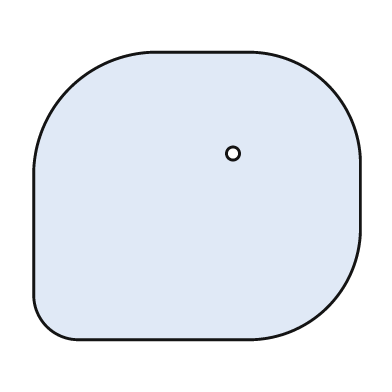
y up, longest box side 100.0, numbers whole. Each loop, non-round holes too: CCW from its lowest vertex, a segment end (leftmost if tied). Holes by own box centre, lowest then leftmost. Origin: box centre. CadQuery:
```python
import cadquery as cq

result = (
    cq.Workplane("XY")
    .moveTo(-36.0, -44.0)
    .lineTo(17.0, -44.0)
    .threePointArc((40.0, -34.0), (50.0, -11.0))
    .lineTo(50.0, 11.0)
    .threePointArc((40.0, 34.0), (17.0, 44.0))
    .lineTo(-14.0, 44.0)
    .threePointArc((-39.0, 33.0), (-50.0, 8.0))
    .lineTo(-50.0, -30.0)
    .threePointArc((-46.0, -40.0), (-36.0, -44.0))
    .close()
    .moveTo(11.0, 13.0)
    .circle(2.0)
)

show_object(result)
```